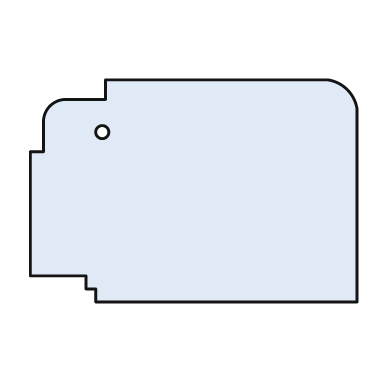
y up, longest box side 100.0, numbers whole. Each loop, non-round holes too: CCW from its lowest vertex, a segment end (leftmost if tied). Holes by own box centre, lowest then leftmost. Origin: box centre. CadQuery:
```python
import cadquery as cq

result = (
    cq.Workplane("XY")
    .moveTo(-30.0, -34.0)
    .lineTo(50.0, -34.0)
    .lineTo(50.0, 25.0)
    .threePointArc((47.0, 31.0), (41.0, 34.0))
    .lineTo(-27.0, 34.0)
    .lineTo(-27.0, 28.0)
    .lineTo(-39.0, 28.0)
    .threePointArc((-44.0, 26.0), (-46.0, 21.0))
    .lineTo(-46.0, 12.0)
    .lineTo(-50.0, 12.0)
    .lineTo(-50.0, -26.0)
    .lineTo(-33.0, -26.0)
    .lineTo(-33.0, -30.0)
    .lineTo(-30.0, -30.0)
    .close()
    .moveTo(-28.0, 18.0)
    .circle(2.0)
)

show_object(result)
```